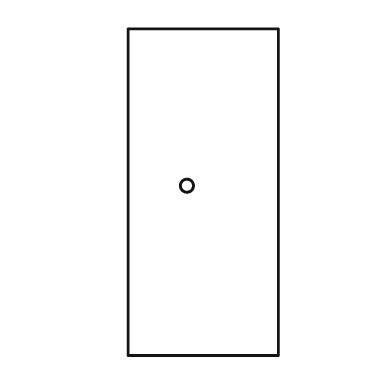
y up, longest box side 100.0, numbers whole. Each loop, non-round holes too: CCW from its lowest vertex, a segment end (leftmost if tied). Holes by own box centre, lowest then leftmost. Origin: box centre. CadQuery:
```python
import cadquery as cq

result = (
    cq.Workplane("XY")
    .moveTo(-23.0, -50.0)
    .lineTo(23.0, -50.0)
    .lineTo(23.0, 50.0)
    .lineTo(-23.0, 50.0)
    .close()
    .moveTo(-5.0, 2.0)
    .circle(2.0)
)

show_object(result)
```